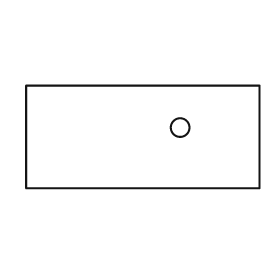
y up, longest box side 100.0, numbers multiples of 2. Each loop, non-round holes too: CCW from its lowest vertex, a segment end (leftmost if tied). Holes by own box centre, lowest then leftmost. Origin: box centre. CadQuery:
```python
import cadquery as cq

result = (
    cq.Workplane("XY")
    .moveTo(-50.0, -22.0)
    .lineTo(50.0, -22.0)
    .lineTo(50.0, 22.0)
    .lineTo(-50.0, 22.0)
    .close()
    .moveTo(16.0, 4.0)
    .circle(4.0)
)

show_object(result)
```